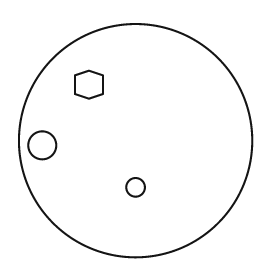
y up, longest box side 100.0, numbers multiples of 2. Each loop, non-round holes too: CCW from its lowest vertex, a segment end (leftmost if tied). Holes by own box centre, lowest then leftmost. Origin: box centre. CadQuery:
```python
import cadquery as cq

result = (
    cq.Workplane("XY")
    .moveTo(0.0, 0.0)
    .circle(50.0)
    .moveTo(0.0, -20.0)
    .circle(4.0)
    .moveTo(-40.0, -2.0)
    .circle(6.0)
    .moveTo(-20.0, 18.0)
    .lineTo(-14.0, 20.0)
    .lineTo(-14.0, 28.0)
    .lineTo(-20.0, 30.0)
    .lineTo(-26.0, 28.0)
    .lineTo(-26.0, 20.0)
    .close()
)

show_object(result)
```